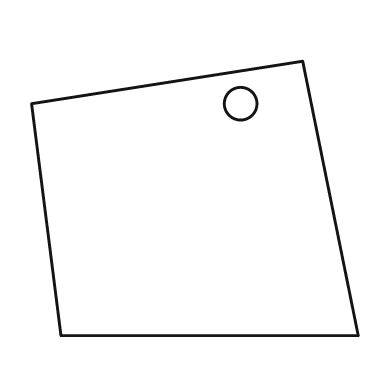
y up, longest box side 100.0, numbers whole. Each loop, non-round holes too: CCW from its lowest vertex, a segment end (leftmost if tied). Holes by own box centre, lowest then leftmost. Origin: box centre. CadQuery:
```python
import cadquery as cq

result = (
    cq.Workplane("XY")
    .moveTo(-41.0, -42.0)
    .lineTo(50.0, -42.0)
    .lineTo(33.0, 42.0)
    .lineTo(-50.0, 29.0)
    .close()
    .moveTo(14.0, 29.0)
    .circle(5.0)
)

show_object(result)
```